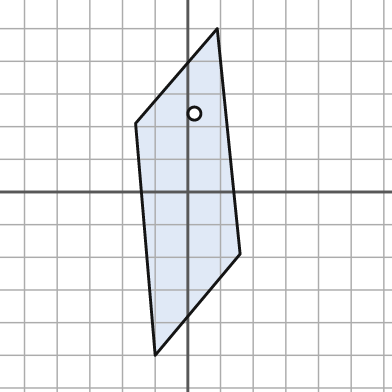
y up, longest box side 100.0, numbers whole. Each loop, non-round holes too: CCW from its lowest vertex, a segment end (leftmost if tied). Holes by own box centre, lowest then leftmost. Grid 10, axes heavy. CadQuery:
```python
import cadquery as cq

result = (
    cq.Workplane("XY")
    .moveTo(-10.0, -50.0)
    .lineTo(16.0, -19.0)
    .lineTo(9.0, 50.0)
    .lineTo(-16.0, 21.0)
    .close()
    .moveTo(2.0, 24.0)
    .circle(2.0)
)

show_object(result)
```